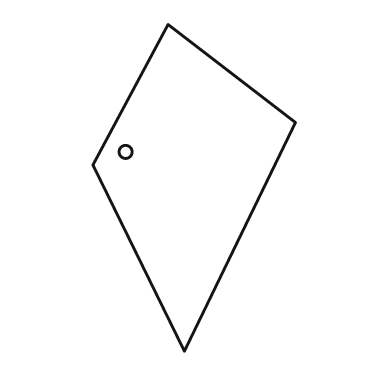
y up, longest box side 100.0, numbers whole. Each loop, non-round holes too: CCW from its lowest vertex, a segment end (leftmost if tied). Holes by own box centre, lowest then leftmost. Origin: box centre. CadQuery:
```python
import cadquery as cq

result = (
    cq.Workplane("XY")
    .moveTo(-3.0, -50.0)
    .lineTo(31.0, 20.0)
    .lineTo(-8.0, 50.0)
    .lineTo(-31.0, 7.0)
    .close()
    .moveTo(-21.0, 11.0)
    .circle(2.0)
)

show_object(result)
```